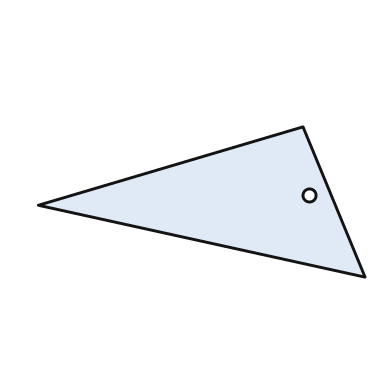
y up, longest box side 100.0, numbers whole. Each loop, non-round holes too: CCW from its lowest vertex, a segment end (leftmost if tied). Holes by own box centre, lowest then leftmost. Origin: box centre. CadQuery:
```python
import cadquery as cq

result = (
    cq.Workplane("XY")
    .moveTo(50.0, -23.0)
    .lineTo(31.0, 23.0)
    .lineTo(-50.0, -1.0)
    .close()
    .moveTo(33.0, 2.0)
    .circle(2.0)
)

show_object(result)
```